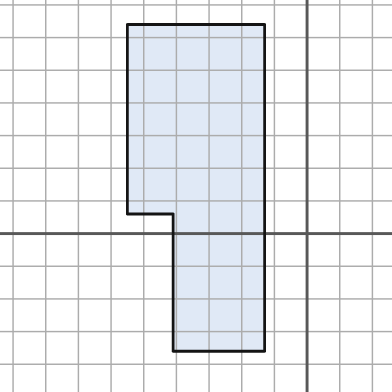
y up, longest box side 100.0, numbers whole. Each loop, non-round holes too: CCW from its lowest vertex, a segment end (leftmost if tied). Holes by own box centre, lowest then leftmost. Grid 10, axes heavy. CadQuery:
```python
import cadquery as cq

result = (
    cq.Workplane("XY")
    .moveTo(-41.0, -36.0)
    .lineTo(-13.0, -36.0)
    .lineTo(-13.0, 64.0)
    .lineTo(-55.0, 64.0)
    .lineTo(-55.0, 6.0)
    .lineTo(-41.0, 6.0)
    .close()
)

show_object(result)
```